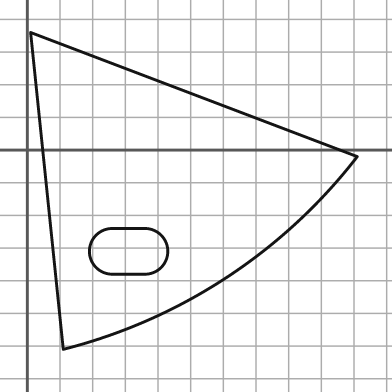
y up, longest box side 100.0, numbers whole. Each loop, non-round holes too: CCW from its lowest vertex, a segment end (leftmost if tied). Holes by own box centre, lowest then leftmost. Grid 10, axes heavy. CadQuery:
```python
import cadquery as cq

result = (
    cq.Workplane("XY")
    .moveTo(11.0, -61.0)
    .threePointArc((61.0, -39.0), (101.0, -2.0))
    .lineTo(1.0, 36.0)
    .close()
    .moveTo(26.0, -38.0)
    .lineTo(36.0, -38.0)
    .threePointArc((43.0, -31.0), (36.0, -24.0))
    .lineTo(26.0, -24.0)
    .threePointArc((19.0, -31.0), (26.0, -38.0))
    .close()
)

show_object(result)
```